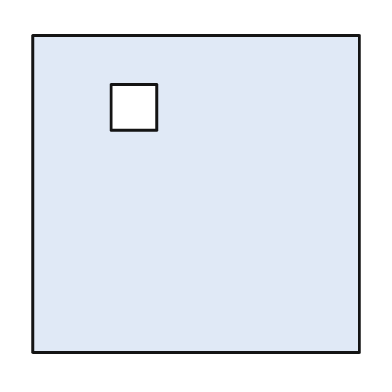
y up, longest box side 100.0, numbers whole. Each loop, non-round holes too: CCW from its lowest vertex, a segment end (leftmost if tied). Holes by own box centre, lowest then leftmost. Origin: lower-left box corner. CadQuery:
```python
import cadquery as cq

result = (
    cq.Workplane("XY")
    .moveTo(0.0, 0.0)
    .lineTo(100.0, 0.0)
    .lineTo(100.0, 97.0)
    .lineTo(0.0, 97.0)
    .close()
    .moveTo(24.0, 68.0)
    .lineTo(38.0, 68.0)
    .lineTo(38.0, 82.0)
    .lineTo(24.0, 82.0)
    .close()
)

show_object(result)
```